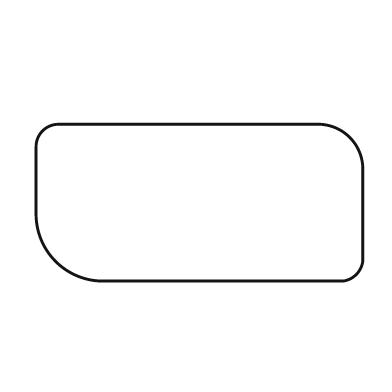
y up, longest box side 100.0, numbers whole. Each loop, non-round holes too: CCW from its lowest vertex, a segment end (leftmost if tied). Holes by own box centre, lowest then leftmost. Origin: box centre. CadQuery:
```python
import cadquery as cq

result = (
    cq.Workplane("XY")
    .moveTo(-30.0, -24.0)
    .lineTo(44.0, -24.0)
    .threePointArc((48.0, -22.0), (50.0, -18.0))
    .lineTo(50.0, 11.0)
    .threePointArc((46.0, 20.0), (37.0, 24.0))
    .lineTo(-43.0, 24.0)
    .threePointArc((-48.0, 22.0), (-50.0, 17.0))
    .lineTo(-50.0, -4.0)
    .threePointArc((-44.0, -18.0), (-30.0, -24.0))
    .close()
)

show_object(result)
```